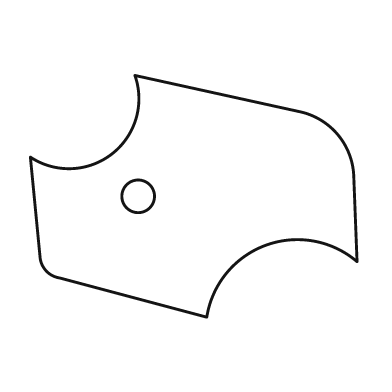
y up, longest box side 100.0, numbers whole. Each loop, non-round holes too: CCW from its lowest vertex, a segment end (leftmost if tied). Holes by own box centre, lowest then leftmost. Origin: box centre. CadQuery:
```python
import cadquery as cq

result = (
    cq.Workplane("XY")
    .moveTo(4.0, -37.0)
    .threePointArc((22.0, -15.0), (50.0, -20.0))
    .lineTo(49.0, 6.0)
    .threePointArc((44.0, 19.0), (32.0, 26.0))
    .lineTo(-18.0, 37.0)
    .threePointArc((-25.0, 13.0), (-50.0, 12.0))
    .lineTo(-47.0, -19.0)
    .threePointArc((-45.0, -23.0), (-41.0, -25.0))
    .close()
    .moveTo(-17.0, 0.0)
    .circle(5.0)
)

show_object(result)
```